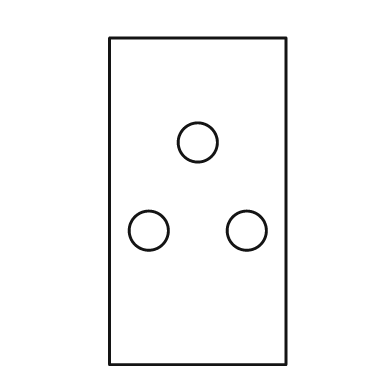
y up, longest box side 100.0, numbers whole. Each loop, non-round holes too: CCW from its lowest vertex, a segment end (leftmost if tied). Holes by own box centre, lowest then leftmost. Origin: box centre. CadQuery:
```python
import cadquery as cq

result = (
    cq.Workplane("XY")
    .moveTo(-27.0, -50.0)
    .lineTo(27.0, -50.0)
    .lineTo(27.0, 50.0)
    .lineTo(-27.0, 50.0)
    .close()
    .moveTo(-15.0, -9.0)
    .circle(6.0)
    .moveTo(15.0, -9.0)
    .circle(6.0)
    .moveTo(0.0, 18.0)
    .circle(6.0)
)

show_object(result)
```